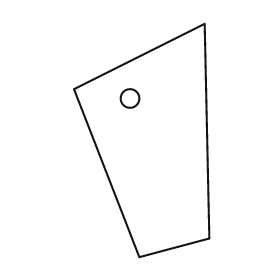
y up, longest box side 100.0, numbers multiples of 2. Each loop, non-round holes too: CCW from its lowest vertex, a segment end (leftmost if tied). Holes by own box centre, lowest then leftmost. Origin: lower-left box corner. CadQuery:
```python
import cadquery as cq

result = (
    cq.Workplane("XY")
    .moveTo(28.0, 0.0)
    .lineTo(58.0, 8.0)
    .lineTo(56.0, 100.0)
    .lineTo(0.0, 72.0)
    .close()
    .moveTo(24.0, 68.0)
    .circle(4.0)
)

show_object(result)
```